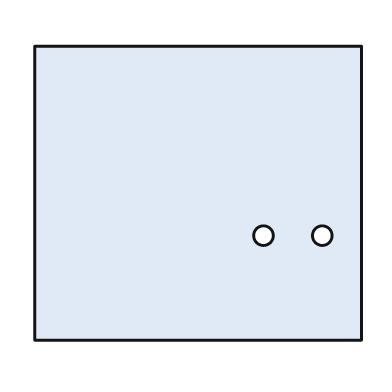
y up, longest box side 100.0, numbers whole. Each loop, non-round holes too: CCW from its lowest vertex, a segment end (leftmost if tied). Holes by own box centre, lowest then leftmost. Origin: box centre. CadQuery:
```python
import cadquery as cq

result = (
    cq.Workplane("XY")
    .moveTo(-50.0, -45.0)
    .lineTo(50.0, -45.0)
    .lineTo(50.0, 45.0)
    .lineTo(-50.0, 45.0)
    .close()
    .moveTo(20.0, -13.0)
    .circle(3.0)
    .moveTo(38.0, -13.0)
    .circle(3.0)
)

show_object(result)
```